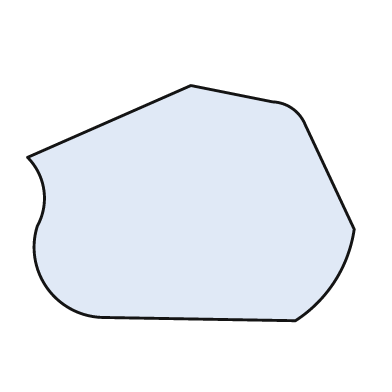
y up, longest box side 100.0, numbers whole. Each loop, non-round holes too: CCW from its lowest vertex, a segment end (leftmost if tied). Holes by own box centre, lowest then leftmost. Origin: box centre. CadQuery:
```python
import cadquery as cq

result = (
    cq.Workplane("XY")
    .moveTo(32.0, -36.0)
    .threePointArc((44.0, -24.0), (50.0, -8.0))
    .lineTo(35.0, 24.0)
    .threePointArc((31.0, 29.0), (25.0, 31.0))
    .lineTo(0.0, 36.0)
    .lineTo(-50.0, 14.0)
    .threePointArc((-45.0, 4.0), (-47.0, -7.0))
    .threePointArc((-44.0, -26.0), (-27.0, -35.0))
    .close()
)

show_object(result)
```